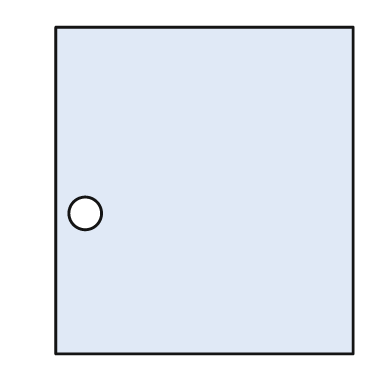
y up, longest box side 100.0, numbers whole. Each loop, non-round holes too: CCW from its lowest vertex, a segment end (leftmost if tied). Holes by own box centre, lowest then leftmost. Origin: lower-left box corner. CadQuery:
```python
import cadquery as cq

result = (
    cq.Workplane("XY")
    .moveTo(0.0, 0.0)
    .lineTo(91.0, 0.0)
    .lineTo(91.0, 100.0)
    .lineTo(0.0, 100.0)
    .close()
    .moveTo(9.0, 43.0)
    .circle(5.0)
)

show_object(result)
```